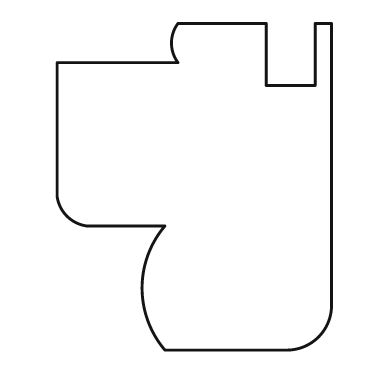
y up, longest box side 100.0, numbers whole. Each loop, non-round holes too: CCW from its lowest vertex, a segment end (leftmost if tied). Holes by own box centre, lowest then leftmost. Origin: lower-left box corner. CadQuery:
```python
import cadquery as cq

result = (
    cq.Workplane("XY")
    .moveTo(33.0, 0.0)
    .lineTo(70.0, 0.0)
    .threePointArc((80.0, 4.0), (84.0, 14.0))
    .lineTo(84.0, 100.0)
    .lineTo(79.0, 100.0)
    .lineTo(79.0, 81.0)
    .lineTo(64.0, 81.0)
    .lineTo(64.0, 100.0)
    .lineTo(37.0, 100.0)
    .threePointArc((35.0, 94.0), (37.0, 88.0))
    .lineTo(0.0, 88.0)
    .lineTo(0.0, 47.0)
    .threePointArc((3.0, 41.0), (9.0, 38.0))
    .lineTo(33.0, 38.0)
    .threePointArc((26.0, 19.0), (33.0, 0.0))
    .close()
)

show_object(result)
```